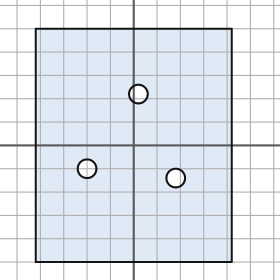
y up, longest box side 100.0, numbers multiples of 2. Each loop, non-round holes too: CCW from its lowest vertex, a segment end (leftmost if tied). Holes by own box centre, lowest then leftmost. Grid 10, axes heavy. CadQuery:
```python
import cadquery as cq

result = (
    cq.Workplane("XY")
    .moveTo(-42.0, -50.0)
    .lineTo(42.0, -50.0)
    .lineTo(42.0, 50.0)
    .lineTo(-42.0, 50.0)
    .close()
    .moveTo(18.0, -14.0)
    .circle(4.0)
    .moveTo(-20.0, -10.0)
    .circle(4.0)
    .moveTo(2.0, 22.0)
    .circle(4.0)
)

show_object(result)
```